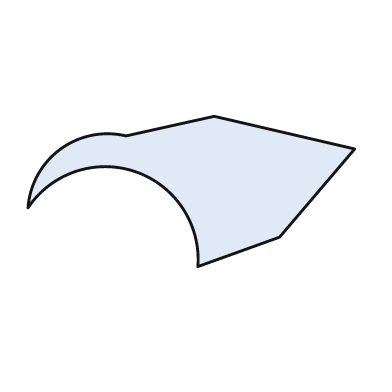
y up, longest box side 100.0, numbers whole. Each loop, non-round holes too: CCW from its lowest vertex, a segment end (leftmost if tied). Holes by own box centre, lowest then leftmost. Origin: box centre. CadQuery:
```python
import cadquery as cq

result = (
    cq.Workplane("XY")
    .moveTo(2.0, -23.0)
    .lineTo(27.0, -14.0)
    .lineTo(50.0, 13.0)
    .lineTo(7.0, 23.0)
    .lineTo(-20.0, 17.0)
    .threePointArc((-40.0, 13.0), (-50.0, -5.0))
    .threePointArc((-17.0, 6.0), (2.0, -23.0))
    .close()
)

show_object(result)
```